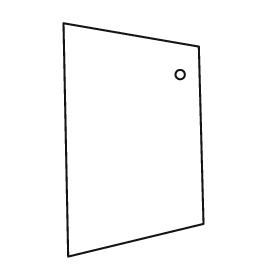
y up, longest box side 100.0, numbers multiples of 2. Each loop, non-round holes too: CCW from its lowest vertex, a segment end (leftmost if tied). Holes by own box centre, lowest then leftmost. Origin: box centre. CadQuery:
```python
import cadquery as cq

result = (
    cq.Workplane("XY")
    .moveTo(-28.0, -50.0)
    .lineTo(30.0, -36.0)
    .lineTo(28.0, 40.0)
    .lineTo(-30.0, 50.0)
    .close()
    .moveTo(20.0, 28.0)
    .circle(2.0)
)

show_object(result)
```